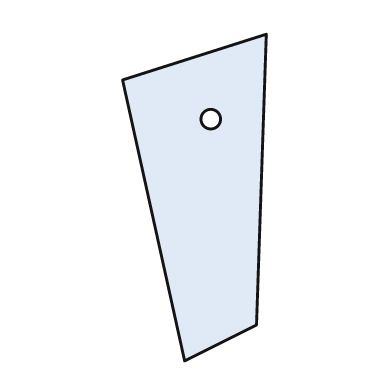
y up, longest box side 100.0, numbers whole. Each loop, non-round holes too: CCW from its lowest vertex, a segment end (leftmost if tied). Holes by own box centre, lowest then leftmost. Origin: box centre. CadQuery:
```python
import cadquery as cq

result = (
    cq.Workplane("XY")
    .moveTo(-3.0, -50.0)
    .lineTo(19.0, -39.0)
    .lineTo(22.0, 50.0)
    .lineTo(-22.0, 36.0)
    .close()
    .moveTo(5.0, 24.0)
    .circle(3.0)
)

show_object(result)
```